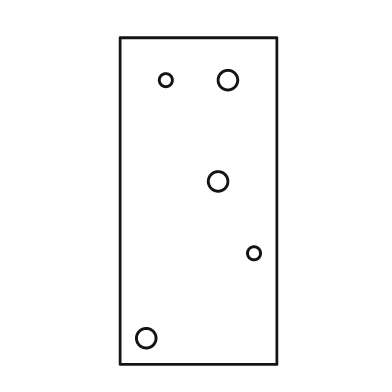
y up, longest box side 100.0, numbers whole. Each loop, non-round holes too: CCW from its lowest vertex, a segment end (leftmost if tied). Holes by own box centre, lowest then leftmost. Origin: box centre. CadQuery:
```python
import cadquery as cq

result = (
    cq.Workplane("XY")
    .moveTo(-24.0, -50.0)
    .lineTo(24.0, -50.0)
    .lineTo(24.0, 50.0)
    .lineTo(-24.0, 50.0)
    .close()
    .moveTo(-16.0, -42.0)
    .circle(3.0)
    .moveTo(17.0, -16.0)
    .circle(2.0)
    .moveTo(6.0, 6.0)
    .circle(3.0)
    .moveTo(-10.0, 37.0)
    .circle(2.0)
    .moveTo(9.0, 37.0)
    .circle(3.0)
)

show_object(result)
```